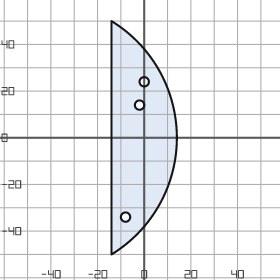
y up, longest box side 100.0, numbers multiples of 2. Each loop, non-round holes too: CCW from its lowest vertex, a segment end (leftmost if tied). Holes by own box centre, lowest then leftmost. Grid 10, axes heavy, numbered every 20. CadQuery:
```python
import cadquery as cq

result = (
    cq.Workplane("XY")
    .moveTo(-14.0, -50.0)
    .threePointArc((14.0, 0.0), (-14.0, 50.0))
    .close()
    .moveTo(-8.0, -34.0)
    .circle(2.0)
    .moveTo(-2.0, 14.0)
    .circle(2.0)
    .moveTo(0.0, 24.0)
    .circle(2.0)
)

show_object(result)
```